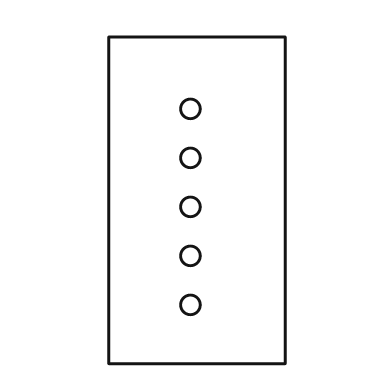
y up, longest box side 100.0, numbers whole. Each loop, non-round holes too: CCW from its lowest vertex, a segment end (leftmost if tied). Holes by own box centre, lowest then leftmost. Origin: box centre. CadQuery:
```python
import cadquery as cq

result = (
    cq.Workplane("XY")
    .moveTo(-27.0, -50.0)
    .lineTo(27.0, -50.0)
    .lineTo(27.0, 50.0)
    .lineTo(-27.0, 50.0)
    .close()
    .moveTo(-2.0, -32.0)
    .circle(3.0)
    .moveTo(-2.0, -17.0)
    .circle(3.0)
    .moveTo(-2.0, -2.0)
    .circle(3.0)
    .moveTo(-2.0, 13.0)
    .circle(3.0)
    .moveTo(-2.0, 28.0)
    .circle(3.0)
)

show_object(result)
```